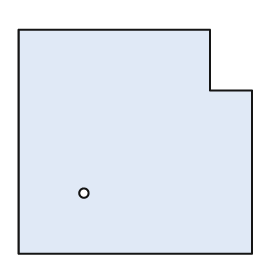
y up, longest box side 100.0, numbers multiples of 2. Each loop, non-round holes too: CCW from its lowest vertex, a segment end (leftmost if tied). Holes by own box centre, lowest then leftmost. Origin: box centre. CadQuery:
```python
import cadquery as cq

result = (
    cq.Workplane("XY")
    .moveTo(-50.0, -48.0)
    .lineTo(50.0, -48.0)
    .lineTo(50.0, 22.0)
    .lineTo(32.0, 22.0)
    .lineTo(32.0, 48.0)
    .lineTo(-50.0, 48.0)
    .close()
    .moveTo(-22.0, -22.0)
    .circle(2.0)
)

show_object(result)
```